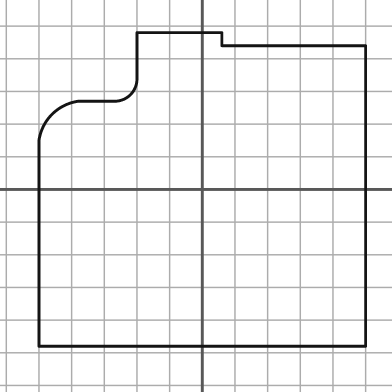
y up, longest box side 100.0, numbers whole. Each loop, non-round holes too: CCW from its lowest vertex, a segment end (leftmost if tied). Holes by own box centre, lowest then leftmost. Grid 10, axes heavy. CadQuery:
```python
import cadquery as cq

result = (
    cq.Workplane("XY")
    .moveTo(-50.0, -48.0)
    .lineTo(50.0, -48.0)
    .lineTo(50.0, 44.0)
    .lineTo(6.0, 44.0)
    .lineTo(6.0, 48.0)
    .lineTo(-20.0, 48.0)
    .lineTo(-20.0, 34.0)
    .threePointArc((-22.0, 29.0), (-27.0, 27.0))
    .lineTo(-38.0, 27.0)
    .threePointArc((-46.0, 23.0), (-50.0, 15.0))
    .close()
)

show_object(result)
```